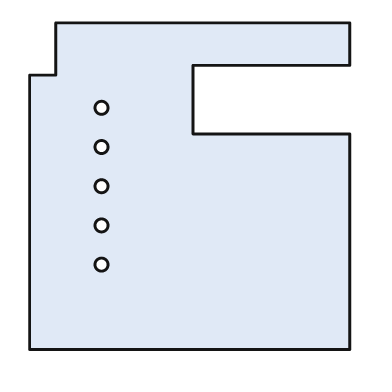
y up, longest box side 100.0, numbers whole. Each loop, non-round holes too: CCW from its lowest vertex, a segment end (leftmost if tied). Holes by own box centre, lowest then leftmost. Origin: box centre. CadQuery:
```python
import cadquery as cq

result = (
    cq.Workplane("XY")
    .moveTo(-49.0, -50.0)
    .lineTo(49.0, -50.0)
    .lineTo(49.0, 16.0)
    .lineTo(1.0, 16.0)
    .lineTo(1.0, 37.0)
    .lineTo(49.0, 37.0)
    .lineTo(49.0, 50.0)
    .lineTo(-41.0, 50.0)
    .lineTo(-41.0, 34.0)
    .lineTo(-49.0, 34.0)
    .close()
    .moveTo(-27.0, -24.0)
    .circle(2.0)
    .moveTo(-27.0, -12.0)
    .circle(2.0)
    .moveTo(-27.0, 0.0)
    .circle(2.0)
    .moveTo(-27.0, 12.0)
    .circle(2.0)
    .moveTo(-27.0, 24.0)
    .circle(2.0)
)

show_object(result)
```